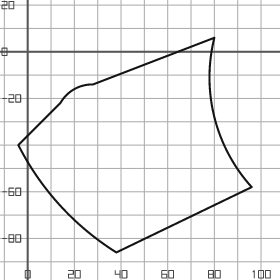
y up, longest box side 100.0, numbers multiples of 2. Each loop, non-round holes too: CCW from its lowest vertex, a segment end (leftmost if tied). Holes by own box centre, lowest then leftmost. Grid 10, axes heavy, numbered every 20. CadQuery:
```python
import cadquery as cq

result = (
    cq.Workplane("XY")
    .moveTo(38.0, -86.0)
    .lineTo(96.0, -58.0)
    .threePointArc((80.0, -28.0), (80.0, 6.0))
    .lineTo(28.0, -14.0)
    .threePointArc((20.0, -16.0), (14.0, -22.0))
    .lineTo(-4.0, -40.0)
    .threePointArc((14.0, -66.0), (38.0, -86.0))
    .close()
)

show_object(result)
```